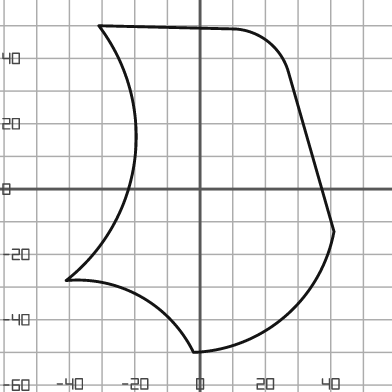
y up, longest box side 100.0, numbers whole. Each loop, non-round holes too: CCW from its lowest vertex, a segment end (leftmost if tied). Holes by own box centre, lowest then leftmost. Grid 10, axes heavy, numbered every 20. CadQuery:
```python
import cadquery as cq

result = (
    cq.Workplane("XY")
    .moveTo(-2.0, -50.0)
    .threePointArc((26.0, -39.0), (41.0, -13.0))
    .lineTo(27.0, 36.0)
    .threePointArc((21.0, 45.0), (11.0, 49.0))
    .lineTo(-31.0, 50.0)
    .threePointArc((-20.0, 9.0), (-41.0, -28.0))
    .threePointArc((-18.0, -33.0), (-2.0, -50.0))
    .close()
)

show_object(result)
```